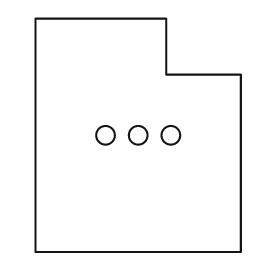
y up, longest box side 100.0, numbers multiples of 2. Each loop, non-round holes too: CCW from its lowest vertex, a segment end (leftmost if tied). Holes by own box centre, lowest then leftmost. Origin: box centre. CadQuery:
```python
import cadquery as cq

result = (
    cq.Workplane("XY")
    .moveTo(-44.0, -50.0)
    .lineTo(44.0, -50.0)
    .lineTo(44.0, 26.0)
    .lineTo(12.0, 26.0)
    .lineTo(12.0, 50.0)
    .lineTo(-44.0, 50.0)
    .close()
    .moveTo(-14.0, 0.0)
    .circle(4.0)
    .moveTo(0.0, 0.0)
    .circle(4.0)
    .moveTo(14.0, 0.0)
    .circle(4.0)
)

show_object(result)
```